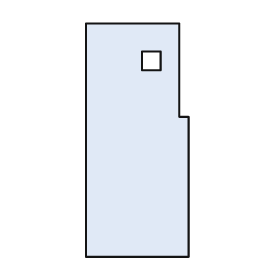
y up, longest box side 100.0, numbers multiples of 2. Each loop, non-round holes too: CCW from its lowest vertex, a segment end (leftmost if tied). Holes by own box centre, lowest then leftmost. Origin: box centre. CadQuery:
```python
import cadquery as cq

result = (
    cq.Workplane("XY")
    .moveTo(-22.0, -50.0)
    .lineTo(22.0, -50.0)
    .lineTo(22.0, 10.0)
    .lineTo(18.0, 10.0)
    .lineTo(18.0, 50.0)
    .lineTo(-22.0, 50.0)
    .close()
    .moveTo(2.0, 30.0)
    .lineTo(10.0, 30.0)
    .lineTo(10.0, 38.0)
    .lineTo(2.0, 38.0)
    .close()
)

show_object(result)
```